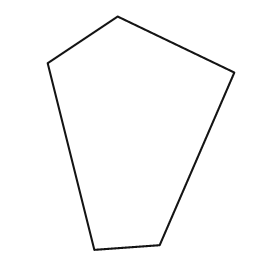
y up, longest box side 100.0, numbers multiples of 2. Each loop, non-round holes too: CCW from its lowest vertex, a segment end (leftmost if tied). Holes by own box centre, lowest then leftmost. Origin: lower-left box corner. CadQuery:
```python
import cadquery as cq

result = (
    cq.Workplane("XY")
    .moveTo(20.0, 0.0)
    .lineTo(48.0, 2.0)
    .lineTo(80.0, 76.0)
    .lineTo(30.0, 100.0)
    .lineTo(0.0, 80.0)
    .close()
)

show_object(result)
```